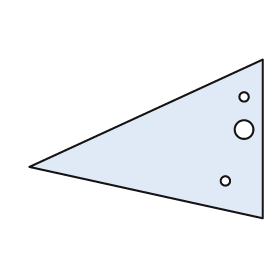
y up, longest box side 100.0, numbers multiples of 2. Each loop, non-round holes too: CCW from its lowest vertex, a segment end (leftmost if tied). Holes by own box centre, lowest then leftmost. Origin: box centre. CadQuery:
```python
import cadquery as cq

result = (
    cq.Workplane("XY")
    .moveTo(50.0, -34.0)
    .lineTo(50.0, 34.0)
    .lineTo(-50.0, -12.0)
    .close()
    .moveTo(34.0, -18.0)
    .circle(2.0)
    .moveTo(42.0, 4.0)
    .circle(4.0)
    .moveTo(42.0, 18.0)
    .circle(2.0)
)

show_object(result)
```